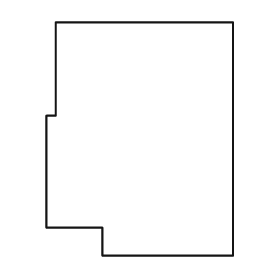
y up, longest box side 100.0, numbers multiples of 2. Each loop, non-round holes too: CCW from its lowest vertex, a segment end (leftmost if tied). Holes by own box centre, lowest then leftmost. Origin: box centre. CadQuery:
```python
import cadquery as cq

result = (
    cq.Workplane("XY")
    .moveTo(-16.0, -50.0)
    .lineTo(40.0, -50.0)
    .lineTo(40.0, 50.0)
    .lineTo(-36.0, 50.0)
    .lineTo(-36.0, 10.0)
    .lineTo(-40.0, 10.0)
    .lineTo(-40.0, -38.0)
    .lineTo(-16.0, -38.0)
    .close()
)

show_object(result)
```